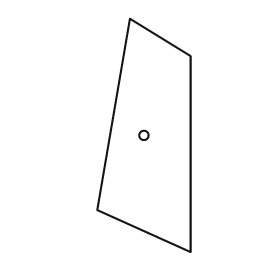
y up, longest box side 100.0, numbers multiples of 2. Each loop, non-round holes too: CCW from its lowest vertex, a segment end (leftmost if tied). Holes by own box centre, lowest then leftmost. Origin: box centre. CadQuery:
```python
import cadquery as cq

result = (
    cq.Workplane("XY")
    .moveTo(20.0, -50.0)
    .lineTo(20.0, 34.0)
    .lineTo(-6.0, 50.0)
    .lineTo(-20.0, -32.0)
    .close()
    .moveTo(0.0, 0.0)
    .circle(2.0)
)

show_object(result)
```